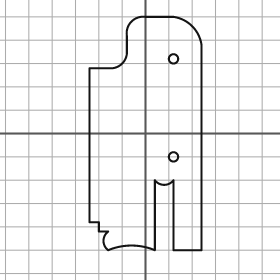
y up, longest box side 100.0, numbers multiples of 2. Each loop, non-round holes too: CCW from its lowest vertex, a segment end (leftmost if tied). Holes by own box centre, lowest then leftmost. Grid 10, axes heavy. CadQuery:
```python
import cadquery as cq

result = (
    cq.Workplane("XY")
    .moveTo(-16.0, -50.0)
    .threePointArc((-6.0, -48.0), (4.0, -50.0))
    .lineTo(4.0, -20.0)
    .threePointArc((8.0, -22.0), (12.0, -20.0))
    .lineTo(12.0, -50.0)
    .lineTo(24.0, -50.0)
    .lineTo(24.0, 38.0)
    .threePointArc((20.0, 46.0), (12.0, 50.0))
    .lineTo(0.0, 50.0)
    .threePointArc((-6.0, 48.0), (-8.0, 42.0))
    .lineTo(-8.0, 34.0)
    .threePointArc((-10.0, 30.0), (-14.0, 28.0))
    .lineTo(-24.0, 28.0)
    .lineTo(-24.0, -38.0)
    .lineTo(-20.0, -38.0)
    .lineTo(-20.0, -42.0)
    .lineTo(-16.0, -42.0)
    .threePointArc((-18.0, -46.0), (-16.0, -50.0))
    .close()
    .moveTo(12.0, -10.0)
    .circle(2.0)
    .moveTo(12.0, 32.0)
    .circle(2.0)
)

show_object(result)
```